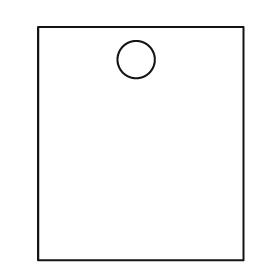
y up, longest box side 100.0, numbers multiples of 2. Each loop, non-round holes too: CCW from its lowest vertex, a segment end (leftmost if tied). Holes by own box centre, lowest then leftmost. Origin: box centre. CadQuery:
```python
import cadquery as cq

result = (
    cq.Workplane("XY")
    .moveTo(-44.0, -50.0)
    .lineTo(44.0, -50.0)
    .lineTo(44.0, 50.0)
    .lineTo(-44.0, 50.0)
    .close()
    .moveTo(-2.0, 36.0)
    .circle(8.0)
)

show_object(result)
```